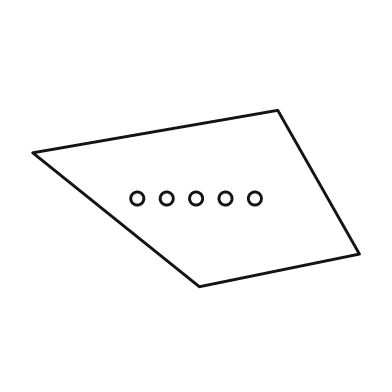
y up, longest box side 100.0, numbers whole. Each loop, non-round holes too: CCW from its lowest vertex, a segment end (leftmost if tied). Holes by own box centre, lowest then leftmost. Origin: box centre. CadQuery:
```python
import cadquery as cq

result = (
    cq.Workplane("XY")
    .moveTo(1.0, -27.0)
    .lineTo(50.0, -17.0)
    .lineTo(25.0, 27.0)
    .lineTo(-50.0, 14.0)
    .close()
    .moveTo(-18.0, 0.0)
    .circle(2.0)
    .moveTo(-9.0, 0.0)
    .circle(2.0)
    .moveTo(0.0, 0.0)
    .circle(2.0)
    .moveTo(9.0, 0.0)
    .circle(2.0)
    .moveTo(18.0, 0.0)
    .circle(2.0)
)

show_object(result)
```